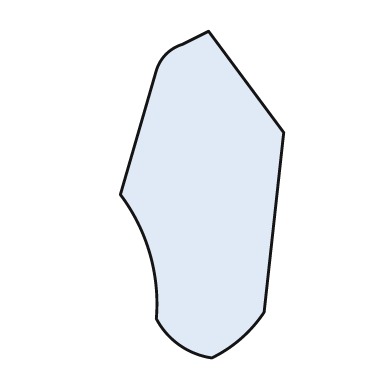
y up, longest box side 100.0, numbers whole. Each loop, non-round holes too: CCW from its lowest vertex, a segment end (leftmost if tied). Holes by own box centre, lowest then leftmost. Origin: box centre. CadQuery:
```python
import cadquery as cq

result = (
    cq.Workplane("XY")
    .moveTo(3.0, -50.0)
    .threePointArc((12.0, -44.0), (19.0, -36.0))
    .lineTo(25.0, 19.0)
    .lineTo(2.0, 50.0)
    .lineTo(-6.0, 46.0)
    .threePointArc((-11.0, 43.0), (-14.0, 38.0))
    .lineTo(-25.0, 0.0)
    .threePointArc((-16.0, -18.0), (-14.0, -38.0))
    .threePointArc((-7.0, -46.0), (3.0, -50.0))
    .close()
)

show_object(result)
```